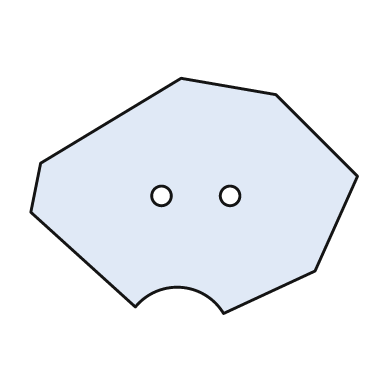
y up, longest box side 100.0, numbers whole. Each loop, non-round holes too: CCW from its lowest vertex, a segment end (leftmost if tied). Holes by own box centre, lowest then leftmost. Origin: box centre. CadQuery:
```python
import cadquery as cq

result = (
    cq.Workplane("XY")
    .moveTo(9.0, -36.0)
    .lineTo(37.0, -23.0)
    .lineTo(50.0, 6.0)
    .lineTo(25.0, 31.0)
    .lineTo(-4.0, 36.0)
    .lineTo(-47.0, 10.0)
    .lineTo(-50.0, -5.0)
    .lineTo(-18.0, -34.0)
    .threePointArc((-4.0, -28.0), (9.0, -36.0))
    .close()
    .moveTo(-10.0, 0.0)
    .circle(3.0)
    .moveTo(11.0, 0.0)
    .circle(3.0)
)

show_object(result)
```